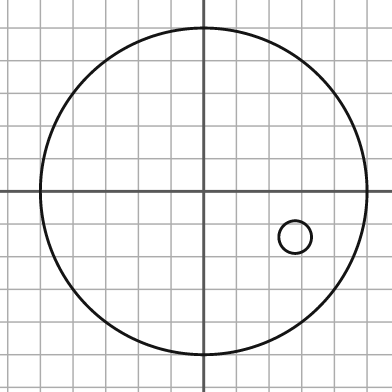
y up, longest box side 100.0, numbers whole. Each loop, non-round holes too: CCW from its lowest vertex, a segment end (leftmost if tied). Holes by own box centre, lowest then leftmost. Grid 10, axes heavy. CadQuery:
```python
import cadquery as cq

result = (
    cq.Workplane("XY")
    .moveTo(0.0, 0.0)
    .circle(50.0)
    .moveTo(28.0, -14.0)
    .circle(5.0)
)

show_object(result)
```